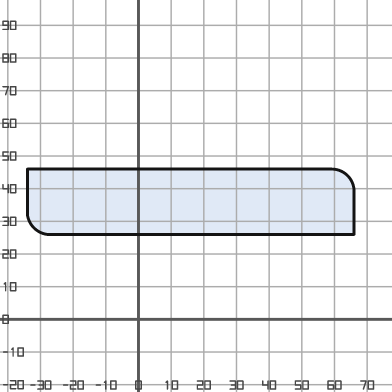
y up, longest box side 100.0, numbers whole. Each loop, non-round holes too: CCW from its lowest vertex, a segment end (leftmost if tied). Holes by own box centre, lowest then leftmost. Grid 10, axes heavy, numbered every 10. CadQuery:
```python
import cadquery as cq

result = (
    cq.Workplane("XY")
    .moveTo(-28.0, 26.0)
    .lineTo(66.0, 26.0)
    .lineTo(66.0, 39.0)
    .threePointArc((64.0, 44.0), (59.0, 46.0))
    .lineTo(-34.0, 46.0)
    .lineTo(-34.0, 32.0)
    .threePointArc((-32.0, 28.0), (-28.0, 26.0))
    .close()
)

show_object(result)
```